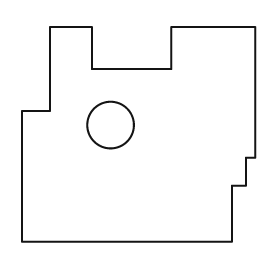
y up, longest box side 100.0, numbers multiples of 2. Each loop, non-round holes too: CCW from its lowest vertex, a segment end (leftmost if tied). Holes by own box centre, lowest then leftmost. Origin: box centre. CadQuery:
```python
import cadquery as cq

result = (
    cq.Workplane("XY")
    .moveTo(-50.0, -46.0)
    .lineTo(40.0, -46.0)
    .lineTo(40.0, -22.0)
    .lineTo(46.0, -22.0)
    .lineTo(46.0, -10.0)
    .lineTo(50.0, -10.0)
    .lineTo(50.0, 46.0)
    .lineTo(14.0, 46.0)
    .lineTo(14.0, 28.0)
    .lineTo(-20.0, 28.0)
    .lineTo(-20.0, 46.0)
    .lineTo(-38.0, 46.0)
    .lineTo(-38.0, 10.0)
    .lineTo(-50.0, 10.0)
    .close()
    .moveTo(-12.0, 4.0)
    .circle(10.0)
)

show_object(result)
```